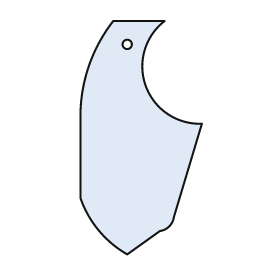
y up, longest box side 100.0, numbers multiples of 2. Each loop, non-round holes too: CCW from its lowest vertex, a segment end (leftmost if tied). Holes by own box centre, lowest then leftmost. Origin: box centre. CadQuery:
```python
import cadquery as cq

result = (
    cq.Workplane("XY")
    .moveTo(-6.0, -50.0)
    .lineTo(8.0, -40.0)
    .threePointArc((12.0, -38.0), (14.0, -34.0))
    .lineTo(26.0, 6.0)
    .threePointArc((2.0, 22.0), (10.0, 50.0))
    .lineTo(-12.0, 50.0)
    .threePointArc((-22.0, 32.0), (-26.0, 12.0))
    .lineTo(-26.0, -26.0)
    .threePointArc((-18.0, -40.0), (-6.0, -50.0))
    .close()
    .moveTo(-6.0, 40.0)
    .circle(2.0)
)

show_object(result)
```